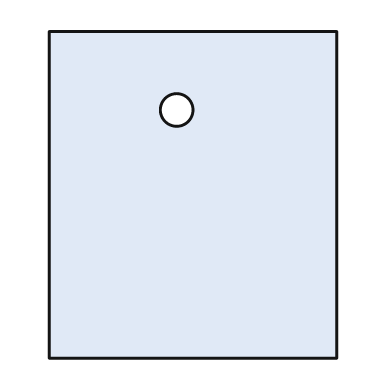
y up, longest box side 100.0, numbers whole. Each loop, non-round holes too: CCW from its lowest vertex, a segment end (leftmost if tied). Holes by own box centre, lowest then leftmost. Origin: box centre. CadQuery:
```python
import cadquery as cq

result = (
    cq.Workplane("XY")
    .moveTo(-44.0, -50.0)
    .lineTo(44.0, -50.0)
    .lineTo(44.0, 50.0)
    .lineTo(-44.0, 50.0)
    .close()
    .moveTo(-5.0, 26.0)
    .circle(5.0)
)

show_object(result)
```